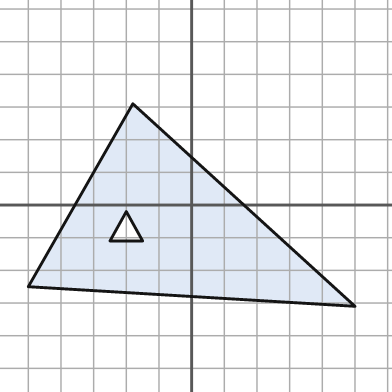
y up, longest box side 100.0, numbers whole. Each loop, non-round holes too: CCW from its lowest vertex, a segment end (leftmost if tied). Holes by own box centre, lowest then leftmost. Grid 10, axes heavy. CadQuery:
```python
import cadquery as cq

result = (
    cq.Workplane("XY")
    .moveTo(50.0, -31.0)
    .lineTo(-18.0, 31.0)
    .lineTo(-50.0, -25.0)
    .close()
    .moveTo(-25.0, -11.0)
    .lineTo(-15.0, -11.0)
    .lineTo(-20.0, -2.0)
    .close()
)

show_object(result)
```